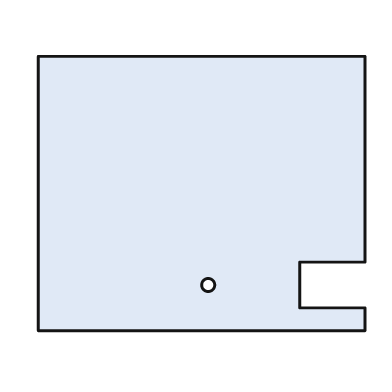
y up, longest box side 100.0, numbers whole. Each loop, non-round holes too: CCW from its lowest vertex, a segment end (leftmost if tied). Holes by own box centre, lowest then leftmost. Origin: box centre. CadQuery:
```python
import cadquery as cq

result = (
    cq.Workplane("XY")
    .moveTo(-50.0, -42.0)
    .lineTo(50.0, -42.0)
    .lineTo(50.0, -35.0)
    .lineTo(30.0, -35.0)
    .lineTo(30.0, -21.0)
    .lineTo(50.0, -21.0)
    .lineTo(50.0, 42.0)
    .lineTo(-50.0, 42.0)
    .close()
    .moveTo(2.0, -28.0)
    .circle(2.0)
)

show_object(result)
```